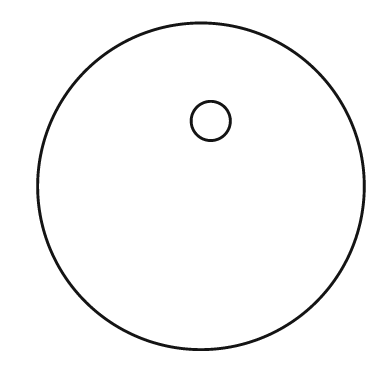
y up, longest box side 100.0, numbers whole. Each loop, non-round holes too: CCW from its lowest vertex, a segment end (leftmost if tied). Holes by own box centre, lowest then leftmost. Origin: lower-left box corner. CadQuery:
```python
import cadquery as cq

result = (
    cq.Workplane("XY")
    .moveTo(50.0, 50.0)
    .circle(50.0)
    .moveTo(53.0, 70.0)
    .circle(6.0)
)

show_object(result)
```